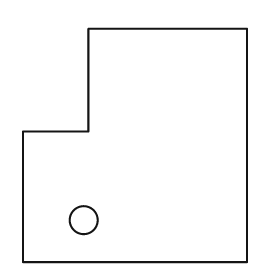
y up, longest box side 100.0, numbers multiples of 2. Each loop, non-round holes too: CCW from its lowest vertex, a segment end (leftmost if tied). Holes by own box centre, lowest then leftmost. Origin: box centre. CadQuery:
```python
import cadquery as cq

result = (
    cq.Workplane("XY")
    .moveTo(-48.0, -50.0)
    .lineTo(48.0, -50.0)
    .lineTo(48.0, 50.0)
    .lineTo(-20.0, 50.0)
    .lineTo(-20.0, 6.0)
    .lineTo(-48.0, 6.0)
    .close()
    .moveTo(-22.0, -32.0)
    .circle(6.0)
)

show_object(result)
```